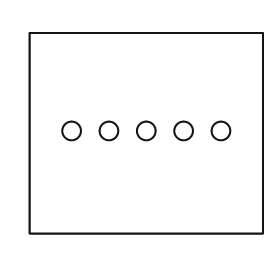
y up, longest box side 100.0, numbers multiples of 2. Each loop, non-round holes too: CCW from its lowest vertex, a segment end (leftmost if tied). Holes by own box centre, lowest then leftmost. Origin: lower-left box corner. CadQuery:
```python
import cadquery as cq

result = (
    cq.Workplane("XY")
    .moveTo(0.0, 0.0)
    .lineTo(100.0, 0.0)
    .lineTo(100.0, 86.0)
    .lineTo(0.0, 86.0)
    .close()
    .moveTo(18.0, 44.0)
    .circle(4.0)
    .moveTo(34.0, 44.0)
    .circle(4.0)
    .moveTo(50.0, 44.0)
    .circle(4.0)
    .moveTo(66.0, 44.0)
    .circle(4.0)
    .moveTo(82.0, 44.0)
    .circle(4.0)
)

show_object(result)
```